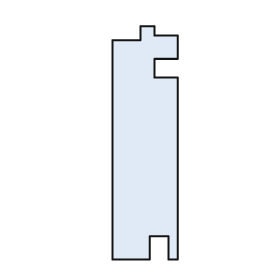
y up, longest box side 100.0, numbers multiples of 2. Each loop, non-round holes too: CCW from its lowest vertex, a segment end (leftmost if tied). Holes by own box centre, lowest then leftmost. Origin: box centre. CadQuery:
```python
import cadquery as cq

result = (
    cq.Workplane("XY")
    .moveTo(-14.0, -50.0)
    .lineTo(2.0, -50.0)
    .lineTo(2.0, -40.0)
    .lineTo(10.0, -40.0)
    .lineTo(10.0, -50.0)
    .lineTo(14.0, -50.0)
    .lineTo(14.0, 28.0)
    .lineTo(4.0, 28.0)
    .lineTo(4.0, 36.0)
    .lineTo(14.0, 36.0)
    .lineTo(14.0, 46.0)
    .lineTo(4.0, 46.0)
    .lineTo(4.0, 50.0)
    .lineTo(-2.0, 50.0)
    .lineTo(-2.0, 44.0)
    .lineTo(-14.0, 44.0)
    .close()
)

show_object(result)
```